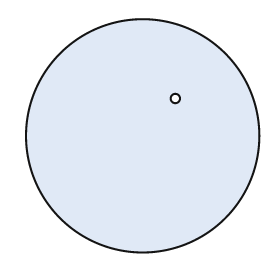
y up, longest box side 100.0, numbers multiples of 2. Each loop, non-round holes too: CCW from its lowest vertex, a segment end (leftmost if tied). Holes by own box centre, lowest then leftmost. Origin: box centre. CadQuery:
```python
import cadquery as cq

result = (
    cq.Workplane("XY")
    .moveTo(0.0, 0.0)
    .circle(50.0)
    .moveTo(14.0, 16.0)
    .circle(2.0)
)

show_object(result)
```